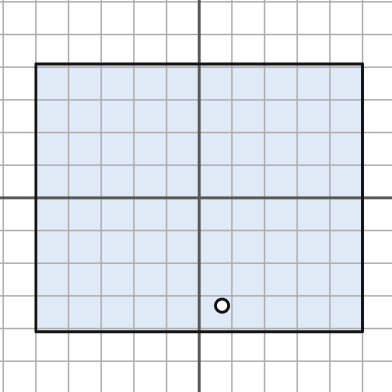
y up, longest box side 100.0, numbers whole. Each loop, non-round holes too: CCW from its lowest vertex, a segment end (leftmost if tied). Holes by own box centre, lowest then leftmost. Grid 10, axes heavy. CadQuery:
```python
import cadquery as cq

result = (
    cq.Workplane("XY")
    .moveTo(-50.0, -41.0)
    .lineTo(50.0, -41.0)
    .lineTo(50.0, 41.0)
    .lineTo(-50.0, 41.0)
    .close()
    .moveTo(7.0, -33.0)
    .circle(2.0)
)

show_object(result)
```